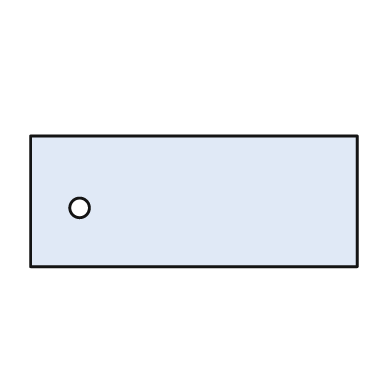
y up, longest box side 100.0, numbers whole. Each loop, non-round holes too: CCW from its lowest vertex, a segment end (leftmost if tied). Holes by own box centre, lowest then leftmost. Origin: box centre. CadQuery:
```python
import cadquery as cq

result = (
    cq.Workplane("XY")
    .moveTo(-50.0, -20.0)
    .lineTo(50.0, -20.0)
    .lineTo(50.0, 20.0)
    .lineTo(-50.0, 20.0)
    .close()
    .moveTo(-35.0, -2.0)
    .circle(3.0)
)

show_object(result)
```